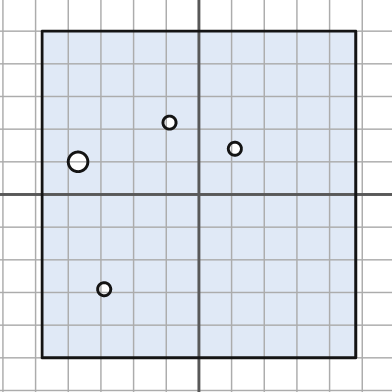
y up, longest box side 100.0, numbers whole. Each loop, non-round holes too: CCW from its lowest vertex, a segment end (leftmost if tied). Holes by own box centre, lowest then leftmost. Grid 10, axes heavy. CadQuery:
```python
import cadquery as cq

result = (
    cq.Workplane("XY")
    .moveTo(-48.0, -50.0)
    .lineTo(48.0, -50.0)
    .lineTo(48.0, 50.0)
    .lineTo(-48.0, 50.0)
    .close()
    .moveTo(-29.0, -29.0)
    .circle(2.0)
    .moveTo(-37.0, 10.0)
    .circle(3.0)
    .moveTo(11.0, 14.0)
    .circle(2.0)
    .moveTo(-9.0, 22.0)
    .circle(2.0)
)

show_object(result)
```